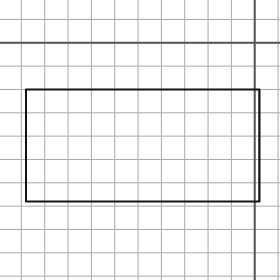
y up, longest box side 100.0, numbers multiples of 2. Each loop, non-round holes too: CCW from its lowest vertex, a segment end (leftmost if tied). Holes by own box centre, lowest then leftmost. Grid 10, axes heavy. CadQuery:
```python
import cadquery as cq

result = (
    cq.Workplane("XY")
    .moveTo(-98.0, -68.0)
    .lineTo(2.0, -68.0)
    .lineTo(2.0, -20.0)
    .lineTo(-98.0, -20.0)
    .close()
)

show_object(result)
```